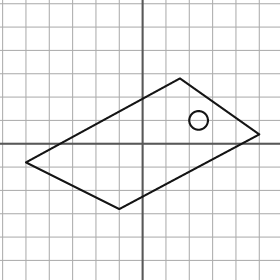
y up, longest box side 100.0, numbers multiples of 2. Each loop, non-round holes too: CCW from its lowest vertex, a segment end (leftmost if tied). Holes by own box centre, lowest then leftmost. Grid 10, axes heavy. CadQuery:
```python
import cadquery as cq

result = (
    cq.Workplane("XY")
    .moveTo(-10.0, -28.0)
    .lineTo(50.0, 4.0)
    .lineTo(16.0, 28.0)
    .lineTo(-50.0, -8.0)
    .close()
    .moveTo(24.0, 10.0)
    .circle(4.0)
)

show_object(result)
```